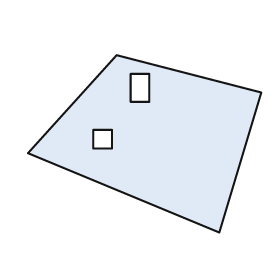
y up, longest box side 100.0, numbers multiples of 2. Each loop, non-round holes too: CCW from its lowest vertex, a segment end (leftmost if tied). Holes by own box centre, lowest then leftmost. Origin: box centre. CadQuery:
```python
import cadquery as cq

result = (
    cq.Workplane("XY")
    .moveTo(32.0, -38.0)
    .lineTo(50.0, 22.0)
    .lineTo(-12.0, 38.0)
    .lineTo(-50.0, -4.0)
    .close()
    .moveTo(-22.0, -2.0)
    .lineTo(-14.0, -2.0)
    .lineTo(-14.0, 6.0)
    .lineTo(-22.0, 6.0)
    .close()
    .moveTo(-6.0, 18.0)
    .lineTo(2.0, 18.0)
    .lineTo(2.0, 30.0)
    .lineTo(-6.0, 30.0)
    .close()
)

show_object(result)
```